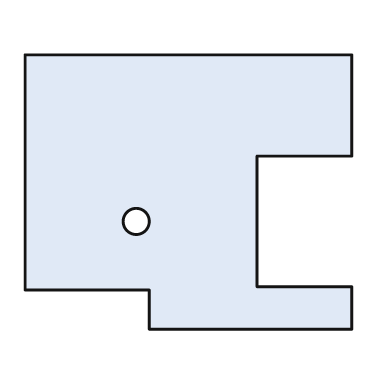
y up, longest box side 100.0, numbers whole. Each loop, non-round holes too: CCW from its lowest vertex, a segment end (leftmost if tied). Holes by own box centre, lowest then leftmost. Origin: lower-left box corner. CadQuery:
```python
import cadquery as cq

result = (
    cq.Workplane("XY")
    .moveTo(38.0, 0.0)
    .lineTo(100.0, 0.0)
    .lineTo(100.0, 13.0)
    .lineTo(71.0, 13.0)
    .lineTo(71.0, 53.0)
    .lineTo(100.0, 53.0)
    .lineTo(100.0, 84.0)
    .lineTo(0.0, 84.0)
    .lineTo(0.0, 12.0)
    .lineTo(38.0, 12.0)
    .close()
    .moveTo(34.0, 33.0)
    .circle(4.0)
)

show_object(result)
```